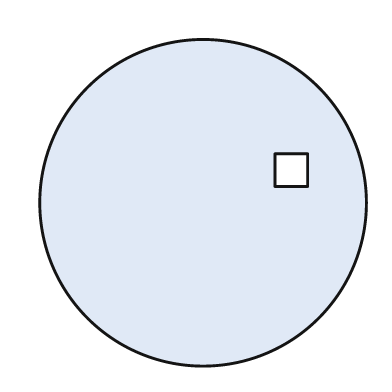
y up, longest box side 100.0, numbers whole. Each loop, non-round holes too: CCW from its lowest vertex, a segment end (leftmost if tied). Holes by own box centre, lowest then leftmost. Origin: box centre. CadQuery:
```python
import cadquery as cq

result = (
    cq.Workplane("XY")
    .moveTo(0.0, 0.0)
    .circle(50.0)
    .moveTo(22.0, 5.0)
    .lineTo(32.0, 5.0)
    .lineTo(32.0, 15.0)
    .lineTo(22.0, 15.0)
    .close()
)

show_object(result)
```